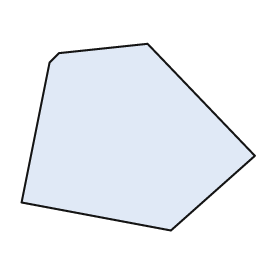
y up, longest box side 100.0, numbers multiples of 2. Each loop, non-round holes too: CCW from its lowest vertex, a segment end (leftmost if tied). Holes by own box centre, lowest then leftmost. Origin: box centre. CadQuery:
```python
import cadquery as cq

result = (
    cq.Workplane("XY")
    .moveTo(14.0, -40.0)
    .lineTo(50.0, -8.0)
    .lineTo(4.0, 40.0)
    .lineTo(-34.0, 36.0)
    .lineTo(-38.0, 32.0)
    .lineTo(-50.0, -28.0)
    .close()
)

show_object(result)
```